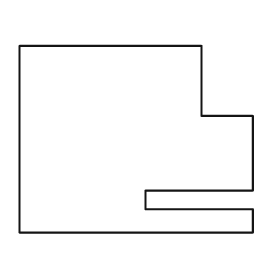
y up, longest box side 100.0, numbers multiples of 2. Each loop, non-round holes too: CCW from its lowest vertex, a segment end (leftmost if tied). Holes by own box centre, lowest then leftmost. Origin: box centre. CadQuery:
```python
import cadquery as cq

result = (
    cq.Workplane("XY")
    .moveTo(-50.0, -40.0)
    .lineTo(50.0, -40.0)
    .lineTo(50.0, -30.0)
    .lineTo(4.0, -30.0)
    .lineTo(4.0, -22.0)
    .lineTo(50.0, -22.0)
    .lineTo(50.0, 10.0)
    .lineTo(28.0, 10.0)
    .lineTo(28.0, 40.0)
    .lineTo(-50.0, 40.0)
    .close()
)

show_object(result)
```